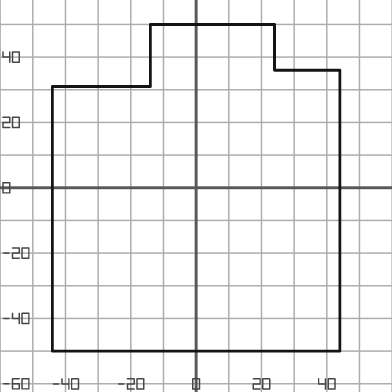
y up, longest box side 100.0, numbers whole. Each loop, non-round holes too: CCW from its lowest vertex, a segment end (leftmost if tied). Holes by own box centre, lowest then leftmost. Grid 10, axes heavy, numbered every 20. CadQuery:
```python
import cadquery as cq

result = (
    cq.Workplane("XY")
    .moveTo(-44.0, -50.0)
    .lineTo(44.0, -50.0)
    .lineTo(44.0, 36.0)
    .lineTo(24.0, 36.0)
    .lineTo(24.0, 50.0)
    .lineTo(-14.0, 50.0)
    .lineTo(-14.0, 31.0)
    .lineTo(-44.0, 31.0)
    .close()
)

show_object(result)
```